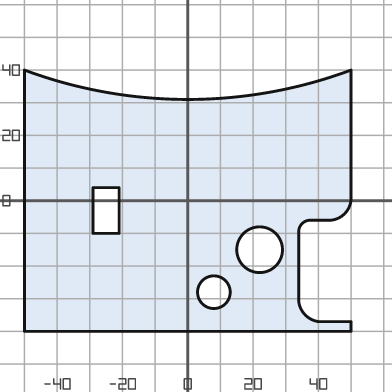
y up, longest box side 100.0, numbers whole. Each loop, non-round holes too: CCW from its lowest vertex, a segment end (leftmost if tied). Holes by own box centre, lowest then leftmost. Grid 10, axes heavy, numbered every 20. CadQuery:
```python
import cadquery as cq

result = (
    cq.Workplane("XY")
    .moveTo(-50.0, -40.0)
    .lineTo(50.0, -40.0)
    .lineTo(50.0, -37.0)
    .lineTo(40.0, -37.0)
    .threePointArc((36.0, -35.0), (34.0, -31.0))
    .lineTo(34.0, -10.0)
    .threePointArc((35.0, -7.0), (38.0, -6.0))
    .lineTo(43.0, -6.0)
    .threePointArc((48.0, -4.0), (50.0, 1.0))
    .lineTo(50.0, 40.0)
    .threePointArc((0.0, 31.0), (-50.0, 40.0))
    .close()
    .moveTo(8.0, -28.0)
    .circle(5.0)
    .moveTo(22.0, -15.0)
    .circle(7.0)
    .moveTo(-29.0, -10.0)
    .lineTo(-21.0, -10.0)
    .lineTo(-21.0, 4.0)
    .lineTo(-29.0, 4.0)
    .close()
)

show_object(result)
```